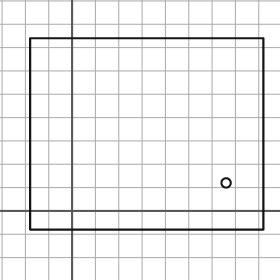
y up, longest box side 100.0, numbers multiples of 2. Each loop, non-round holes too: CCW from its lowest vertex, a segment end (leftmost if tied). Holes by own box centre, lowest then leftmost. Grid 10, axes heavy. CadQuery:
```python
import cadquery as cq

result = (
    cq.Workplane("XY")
    .moveTo(-18.0, -8.0)
    .lineTo(82.0, -8.0)
    .lineTo(82.0, 74.0)
    .lineTo(-18.0, 74.0)
    .close()
    .moveTo(66.0, 12.0)
    .circle(2.0)
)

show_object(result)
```